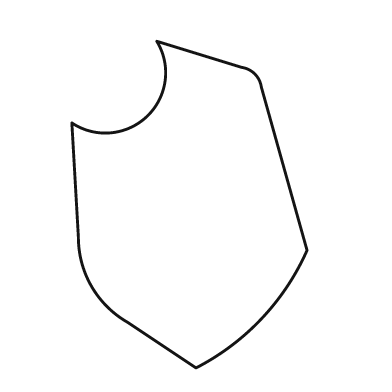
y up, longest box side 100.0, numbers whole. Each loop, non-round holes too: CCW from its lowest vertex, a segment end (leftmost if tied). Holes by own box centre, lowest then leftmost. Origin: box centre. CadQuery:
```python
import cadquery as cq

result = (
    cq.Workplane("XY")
    .moveTo(2.0, -50.0)
    .threePointArc((22.0, -35.0), (36.0, -14.0))
    .lineTo(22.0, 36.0)
    .threePointArc((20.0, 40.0), (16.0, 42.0))
    .lineTo(-10.0, 50.0)
    .threePointArc((-13.0, 27.0), (-36.0, 25.0))
    .lineTo(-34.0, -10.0)
    .threePointArc((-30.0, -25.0), (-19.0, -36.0))
    .close()
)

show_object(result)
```